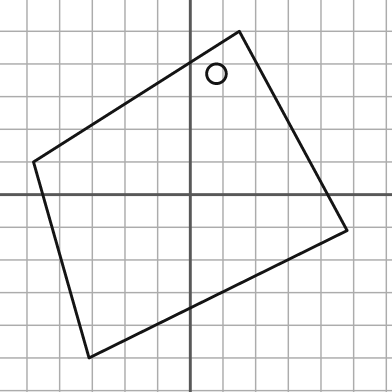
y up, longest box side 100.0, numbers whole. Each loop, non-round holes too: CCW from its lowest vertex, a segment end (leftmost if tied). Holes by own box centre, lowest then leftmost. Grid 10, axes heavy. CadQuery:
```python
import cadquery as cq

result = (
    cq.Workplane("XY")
    .moveTo(-31.0, -50.0)
    .lineTo(48.0, -11.0)
    .lineTo(15.0, 50.0)
    .lineTo(-48.0, 10.0)
    .close()
    .moveTo(8.0, 37.0)
    .circle(3.0)
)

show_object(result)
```